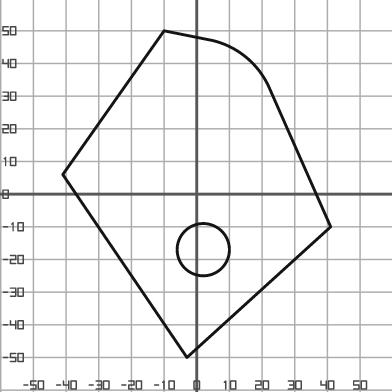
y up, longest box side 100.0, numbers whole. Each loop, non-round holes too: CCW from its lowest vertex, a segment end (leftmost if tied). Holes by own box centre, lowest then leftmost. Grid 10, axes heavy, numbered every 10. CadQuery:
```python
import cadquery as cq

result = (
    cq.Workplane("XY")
    .moveTo(-3.0, -50.0)
    .lineTo(41.0, -10.0)
    .lineTo(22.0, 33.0)
    .threePointArc((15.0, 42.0), (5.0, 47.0))
    .lineTo(-10.0, 50.0)
    .lineTo(-41.0, 6.0)
    .close()
    .moveTo(2.0, -17.0)
    .circle(8.0)
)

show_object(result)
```